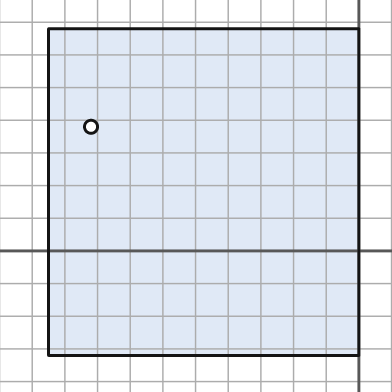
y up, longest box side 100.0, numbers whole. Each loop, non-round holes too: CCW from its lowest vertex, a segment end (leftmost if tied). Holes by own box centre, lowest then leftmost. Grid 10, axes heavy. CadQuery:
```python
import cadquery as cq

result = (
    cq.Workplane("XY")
    .moveTo(-95.0, -32.0)
    .lineTo(0.0, -32.0)
    .lineTo(0.0, 68.0)
    .lineTo(-95.0, 68.0)
    .close()
    .moveTo(-82.0, 38.0)
    .circle(2.0)
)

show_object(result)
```